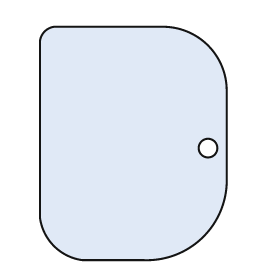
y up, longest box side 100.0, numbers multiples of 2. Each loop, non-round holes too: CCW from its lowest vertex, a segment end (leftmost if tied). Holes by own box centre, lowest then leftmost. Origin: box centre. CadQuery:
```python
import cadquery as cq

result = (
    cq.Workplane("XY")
    .moveTo(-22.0, -50.0)
    .lineTo(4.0, -50.0)
    .threePointArc((30.0, -40.0), (40.0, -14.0))
    .lineTo(40.0, 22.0)
    .threePointArc((32.0, 42.0), (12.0, 50.0))
    .lineTo(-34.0, 50.0)
    .threePointArc((-38.0, 48.0), (-40.0, 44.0))
    .lineTo(-40.0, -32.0)
    .threePointArc((-34.0, -44.0), (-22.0, -50.0))
    .close()
    .moveTo(32.0, -2.0)
    .circle(4.0)
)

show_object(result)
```